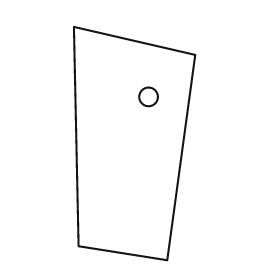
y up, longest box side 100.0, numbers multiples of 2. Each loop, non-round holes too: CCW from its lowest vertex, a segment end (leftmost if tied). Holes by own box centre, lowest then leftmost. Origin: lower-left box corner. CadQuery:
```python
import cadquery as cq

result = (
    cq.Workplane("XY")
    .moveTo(40.0, 0.0)
    .lineTo(52.0, 88.0)
    .lineTo(0.0, 100.0)
    .lineTo(2.0, 6.0)
    .close()
    .moveTo(32.0, 70.0)
    .circle(4.0)
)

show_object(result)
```